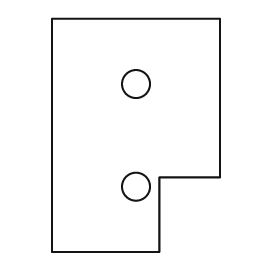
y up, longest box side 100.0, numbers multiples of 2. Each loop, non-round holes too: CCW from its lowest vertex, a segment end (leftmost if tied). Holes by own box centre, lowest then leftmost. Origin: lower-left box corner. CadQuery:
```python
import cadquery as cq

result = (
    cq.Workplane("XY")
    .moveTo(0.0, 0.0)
    .lineTo(46.0, 0.0)
    .lineTo(46.0, 32.0)
    .lineTo(72.0, 32.0)
    .lineTo(72.0, 100.0)
    .lineTo(0.0, 100.0)
    .close()
    .moveTo(36.0, 28.0)
    .circle(6.0)
    .moveTo(36.0, 72.0)
    .circle(6.0)
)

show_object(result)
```